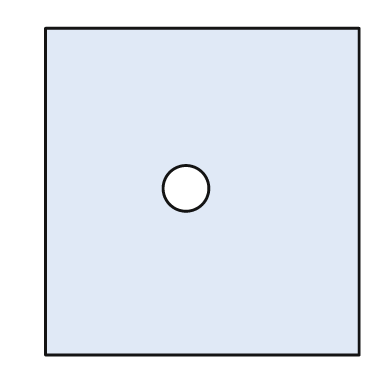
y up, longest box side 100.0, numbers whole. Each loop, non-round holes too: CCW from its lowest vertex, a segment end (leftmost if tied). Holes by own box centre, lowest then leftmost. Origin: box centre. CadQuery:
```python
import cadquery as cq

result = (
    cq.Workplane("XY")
    .moveTo(-48.0, -50.0)
    .lineTo(48.0, -50.0)
    .lineTo(48.0, 50.0)
    .lineTo(-48.0, 50.0)
    .close()
    .moveTo(-5.0, 1.0)
    .circle(7.0)
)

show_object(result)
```